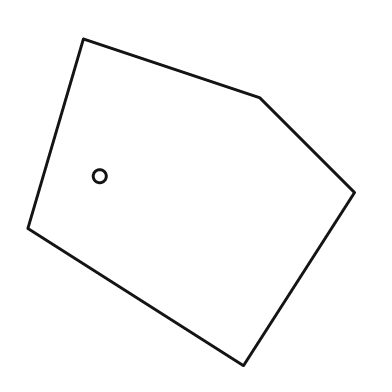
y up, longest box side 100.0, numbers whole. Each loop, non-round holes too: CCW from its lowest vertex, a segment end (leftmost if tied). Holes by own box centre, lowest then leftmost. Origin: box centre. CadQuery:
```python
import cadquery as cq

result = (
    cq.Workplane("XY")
    .moveTo(16.0, -50.0)
    .lineTo(50.0, 3.0)
    .lineTo(21.0, 32.0)
    .lineTo(-33.0, 50.0)
    .lineTo(-50.0, -8.0)
    .close()
    .moveTo(-28.0, 8.0)
    .circle(2.0)
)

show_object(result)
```